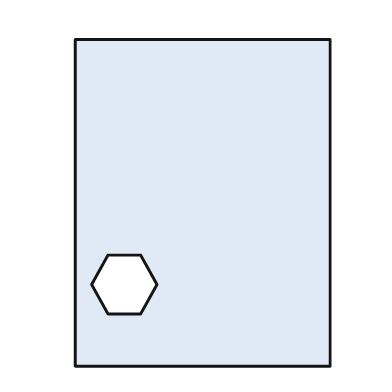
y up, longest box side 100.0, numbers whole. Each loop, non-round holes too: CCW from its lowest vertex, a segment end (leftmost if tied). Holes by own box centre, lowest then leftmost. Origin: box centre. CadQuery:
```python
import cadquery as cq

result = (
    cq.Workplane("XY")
    .moveTo(-39.0, -50.0)
    .lineTo(39.0, -50.0)
    .lineTo(39.0, 50.0)
    .lineTo(-39.0, 50.0)
    .close()
    .moveTo(-29.0, -34.0)
    .lineTo(-19.0, -34.0)
    .lineTo(-14.0, -25.0)
    .lineTo(-19.0, -16.0)
    .lineTo(-29.0, -16.0)
    .lineTo(-34.0, -25.0)
    .close()
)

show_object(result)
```